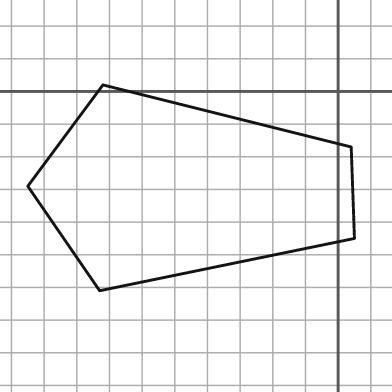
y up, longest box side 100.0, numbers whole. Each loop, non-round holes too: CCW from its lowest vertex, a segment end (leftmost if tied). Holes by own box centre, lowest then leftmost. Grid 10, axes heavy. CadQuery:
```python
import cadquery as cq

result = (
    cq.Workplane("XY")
    .moveTo(-73.0, -61.0)
    .lineTo(5.0, -45.0)
    .lineTo(4.0, -17.0)
    .lineTo(-72.0, 2.0)
    .lineTo(-95.0, -29.0)
    .close()
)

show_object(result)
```